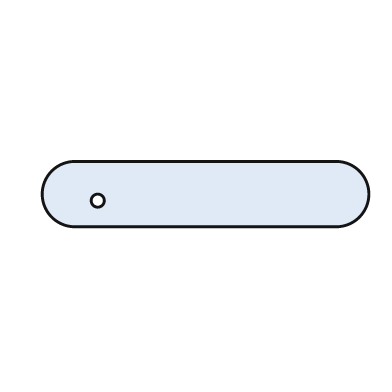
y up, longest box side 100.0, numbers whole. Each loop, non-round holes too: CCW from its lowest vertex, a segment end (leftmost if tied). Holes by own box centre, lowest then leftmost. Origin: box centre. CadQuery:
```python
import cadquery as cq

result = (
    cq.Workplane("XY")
    .moveTo(-40.0, -10.0)
    .lineTo(40.0, -10.0)
    .threePointArc((50.0, 0.0), (40.0, 10.0))
    .lineTo(-40.0, 10.0)
    .threePointArc((-50.0, 0.0), (-40.0, -10.0))
    .close()
    .moveTo(-33.0, -2.0)
    .circle(2.0)
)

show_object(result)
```